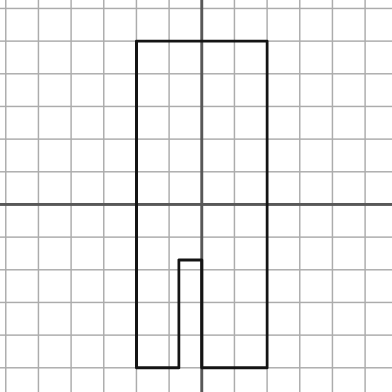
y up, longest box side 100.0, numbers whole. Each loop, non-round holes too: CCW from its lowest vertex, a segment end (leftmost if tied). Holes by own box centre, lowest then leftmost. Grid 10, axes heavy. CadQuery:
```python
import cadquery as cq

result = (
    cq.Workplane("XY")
    .moveTo(-20.0, -50.0)
    .lineTo(-7.0, -50.0)
    .lineTo(-7.0, -17.0)
    .lineTo(0.0, -17.0)
    .lineTo(0.0, -50.0)
    .lineTo(20.0, -50.0)
    .lineTo(20.0, 50.0)
    .lineTo(-20.0, 50.0)
    .close()
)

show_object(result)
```